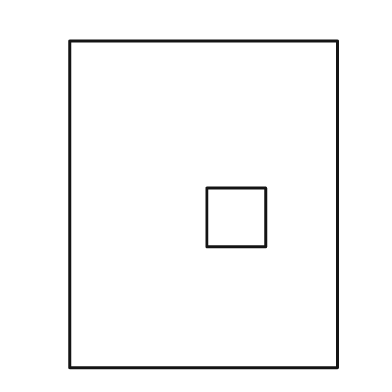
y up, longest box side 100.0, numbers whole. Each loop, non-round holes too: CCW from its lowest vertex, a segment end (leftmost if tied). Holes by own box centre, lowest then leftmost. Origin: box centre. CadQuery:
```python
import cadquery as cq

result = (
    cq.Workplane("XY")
    .moveTo(-41.0, -50.0)
    .lineTo(41.0, -50.0)
    .lineTo(41.0, 50.0)
    .lineTo(-41.0, 50.0)
    .close()
    .moveTo(1.0, -13.0)
    .lineTo(19.0, -13.0)
    .lineTo(19.0, 5.0)
    .lineTo(1.0, 5.0)
    .close()
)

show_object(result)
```